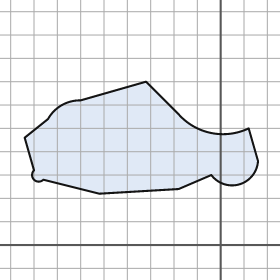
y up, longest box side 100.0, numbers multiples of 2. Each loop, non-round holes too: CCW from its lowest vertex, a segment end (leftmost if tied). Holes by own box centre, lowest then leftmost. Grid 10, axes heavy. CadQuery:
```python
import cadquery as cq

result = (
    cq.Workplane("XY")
    .moveTo(-52.0, 22.0)
    .lineTo(-18.0, 24.0)
    .lineTo(-4.0, 30.0)
    .threePointArc((8.0, 26.0), (16.0, 36.0))
    .lineTo(12.0, 50.0)
    .threePointArc((-4.0, 48.0), (-18.0, 56.0))
    .lineTo(-32.0, 70.0)
    .lineTo(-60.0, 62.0)
    .threePointArc((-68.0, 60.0), (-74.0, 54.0))
    .lineTo(-84.0, 46.0)
    .lineTo(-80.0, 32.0)
    .threePointArc((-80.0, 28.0), (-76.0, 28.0))
    .close()
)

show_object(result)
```